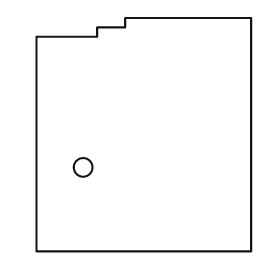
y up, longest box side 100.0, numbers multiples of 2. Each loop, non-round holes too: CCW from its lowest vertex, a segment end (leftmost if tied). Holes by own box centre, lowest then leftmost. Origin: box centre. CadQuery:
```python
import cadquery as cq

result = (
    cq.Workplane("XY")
    .moveTo(-46.0, -50.0)
    .lineTo(46.0, -50.0)
    .lineTo(46.0, 50.0)
    .lineTo(-8.0, 50.0)
    .lineTo(-8.0, 46.0)
    .lineTo(-20.0, 46.0)
    .lineTo(-20.0, 42.0)
    .lineTo(-46.0, 42.0)
    .close()
    .moveTo(-26.0, -14.0)
    .circle(4.0)
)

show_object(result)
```